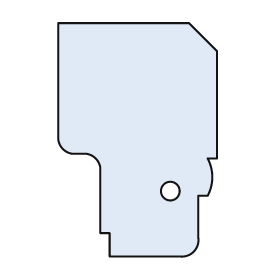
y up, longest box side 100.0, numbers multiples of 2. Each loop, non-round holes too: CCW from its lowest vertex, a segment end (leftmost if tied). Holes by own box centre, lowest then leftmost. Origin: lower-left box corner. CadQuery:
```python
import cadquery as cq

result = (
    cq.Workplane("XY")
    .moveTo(22.0, 0.0)
    .lineTo(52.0, 0.0)
    .threePointArc((58.0, 2.0), (60.0, 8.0))
    .lineTo(60.0, 26.0)
    .lineTo(64.0, 26.0)
    .threePointArc((66.0, 34.0), (64.0, 42.0))
    .lineTo(68.0, 42.0)
    .lineTo(68.0, 88.0)
    .lineTo(56.0, 100.0)
    .lineTo(0.0, 100.0)
    .lineTo(0.0, 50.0)
    .threePointArc((2.0, 46.0), (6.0, 44.0))
    .lineTo(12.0, 44.0)
    .threePointArc((16.0, 42.0), (18.0, 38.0))
    .lineTo(18.0, 10.0)
    .lineTo(22.0, 10.0)
    .close()
    .moveTo(48.0, 28.0)
    .circle(4.0)
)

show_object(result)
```